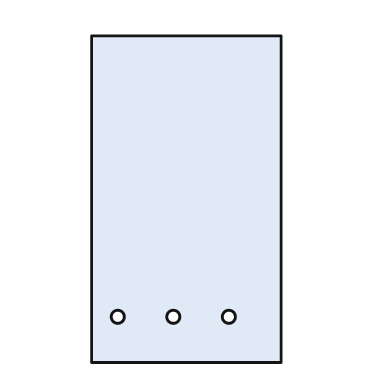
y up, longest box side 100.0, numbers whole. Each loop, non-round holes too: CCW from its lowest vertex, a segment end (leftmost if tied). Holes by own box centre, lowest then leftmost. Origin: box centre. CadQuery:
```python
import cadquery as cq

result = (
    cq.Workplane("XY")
    .moveTo(-29.0, -50.0)
    .lineTo(29.0, -50.0)
    .lineTo(29.0, 50.0)
    .lineTo(-29.0, 50.0)
    .close()
    .moveTo(-21.0, -36.0)
    .circle(2.0)
    .moveTo(-4.0, -36.0)
    .circle(2.0)
    .moveTo(13.0, -36.0)
    .circle(2.0)
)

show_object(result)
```